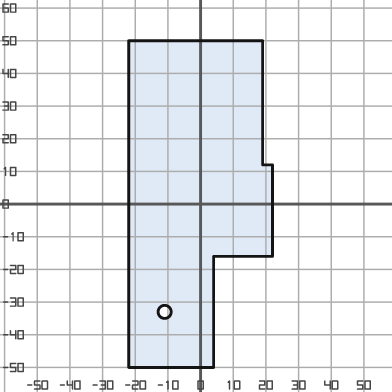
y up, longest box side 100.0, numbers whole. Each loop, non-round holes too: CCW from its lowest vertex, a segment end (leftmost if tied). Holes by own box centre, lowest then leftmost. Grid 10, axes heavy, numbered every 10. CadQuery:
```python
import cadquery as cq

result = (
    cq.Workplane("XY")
    .moveTo(-22.0, -50.0)
    .lineTo(4.0, -50.0)
    .lineTo(4.0, -16.0)
    .lineTo(22.0, -16.0)
    .lineTo(22.0, 12.0)
    .lineTo(19.0, 12.0)
    .lineTo(19.0, 50.0)
    .lineTo(-22.0, 50.0)
    .close()
    .moveTo(-11.0, -33.0)
    .circle(2.0)
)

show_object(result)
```